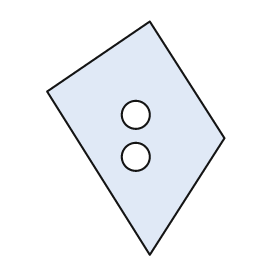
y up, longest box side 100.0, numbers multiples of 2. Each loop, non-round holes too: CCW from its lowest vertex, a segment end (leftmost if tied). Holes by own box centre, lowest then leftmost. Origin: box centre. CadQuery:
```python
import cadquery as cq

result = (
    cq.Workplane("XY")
    .moveTo(6.0, -50.0)
    .lineTo(38.0, 0.0)
    .lineTo(6.0, 50.0)
    .lineTo(-38.0, 20.0)
    .close()
    .moveTo(0.0, -8.0)
    .circle(6.0)
    .moveTo(0.0, 10.0)
    .circle(6.0)
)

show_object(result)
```